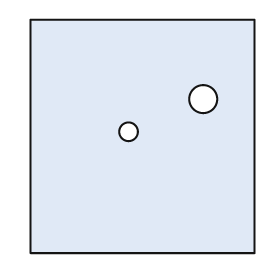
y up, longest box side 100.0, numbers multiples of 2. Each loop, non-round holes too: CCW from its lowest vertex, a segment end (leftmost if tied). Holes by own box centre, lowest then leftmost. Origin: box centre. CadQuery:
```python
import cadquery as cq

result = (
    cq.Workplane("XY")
    .moveTo(-48.0, -50.0)
    .lineTo(48.0, -50.0)
    .lineTo(48.0, 50.0)
    .lineTo(-48.0, 50.0)
    .close()
    .moveTo(-6.0, 2.0)
    .circle(4.0)
    .moveTo(26.0, 16.0)
    .circle(6.0)
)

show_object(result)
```